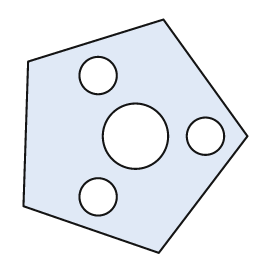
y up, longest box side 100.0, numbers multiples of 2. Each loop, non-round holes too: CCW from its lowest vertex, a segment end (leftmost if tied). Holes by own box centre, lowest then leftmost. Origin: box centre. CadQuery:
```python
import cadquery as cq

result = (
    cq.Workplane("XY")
    .moveTo(10.0, -50.0)
    .lineTo(48.0, 0.0)
    .lineTo(12.0, 50.0)
    .lineTo(-46.0, 32.0)
    .lineTo(-48.0, -30.0)
    .close()
    .moveTo(-16.0, -26.0)
    .circle(8.0)
    .moveTo(0.0, 0.0)
    .circle(14.0)
    .moveTo(30.0, 0.0)
    .circle(8.0)
    .moveTo(-16.0, 26.0)
    .circle(8.0)
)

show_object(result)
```